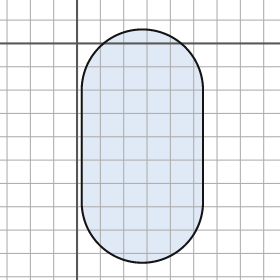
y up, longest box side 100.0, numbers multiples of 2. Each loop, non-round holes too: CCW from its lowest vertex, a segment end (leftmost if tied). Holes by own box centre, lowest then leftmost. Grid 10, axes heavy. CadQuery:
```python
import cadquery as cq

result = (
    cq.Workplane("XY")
    .moveTo(2.0, -68.0)
    .threePointArc((28.0, -94.0), (54.0, -68.0))
    .lineTo(54.0, -20.0)
    .threePointArc((28.0, 6.0), (2.0, -20.0))
    .close()
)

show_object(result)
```